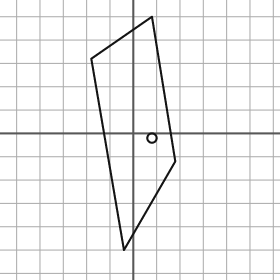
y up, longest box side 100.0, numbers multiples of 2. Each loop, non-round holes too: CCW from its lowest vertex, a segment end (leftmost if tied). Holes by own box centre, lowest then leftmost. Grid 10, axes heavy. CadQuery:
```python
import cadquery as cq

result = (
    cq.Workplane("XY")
    .moveTo(-4.0, -50.0)
    .lineTo(18.0, -12.0)
    .lineTo(8.0, 50.0)
    .lineTo(-18.0, 32.0)
    .close()
    .moveTo(8.0, -2.0)
    .circle(2.0)
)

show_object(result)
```